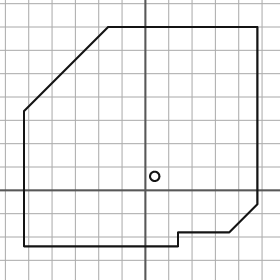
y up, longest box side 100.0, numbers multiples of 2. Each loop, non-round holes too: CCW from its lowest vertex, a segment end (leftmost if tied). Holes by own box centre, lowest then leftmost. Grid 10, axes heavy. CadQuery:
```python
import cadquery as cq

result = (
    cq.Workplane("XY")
    .moveTo(-52.0, -24.0)
    .lineTo(14.0, -24.0)
    .lineTo(14.0, -18.0)
    .lineTo(36.0, -18.0)
    .lineTo(48.0, -6.0)
    .lineTo(48.0, 70.0)
    .lineTo(-16.0, 70.0)
    .lineTo(-52.0, 34.0)
    .close()
    .moveTo(4.0, 6.0)
    .circle(2.0)
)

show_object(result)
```